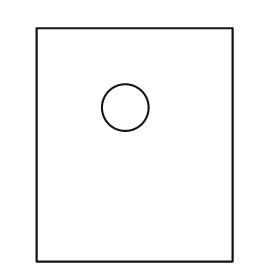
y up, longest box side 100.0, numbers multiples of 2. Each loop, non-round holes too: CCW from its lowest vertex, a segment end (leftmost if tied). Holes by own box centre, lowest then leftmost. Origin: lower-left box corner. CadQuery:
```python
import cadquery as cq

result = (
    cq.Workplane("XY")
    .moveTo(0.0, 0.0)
    .lineTo(84.0, 0.0)
    .lineTo(84.0, 100.0)
    .lineTo(0.0, 100.0)
    .close()
    .moveTo(38.0, 66.0)
    .circle(10.0)
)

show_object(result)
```